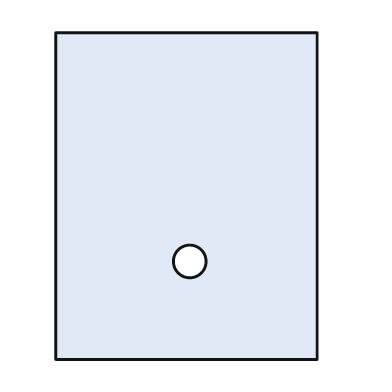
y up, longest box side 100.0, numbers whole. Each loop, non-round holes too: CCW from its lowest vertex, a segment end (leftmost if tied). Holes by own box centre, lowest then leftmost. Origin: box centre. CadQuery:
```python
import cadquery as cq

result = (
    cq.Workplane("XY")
    .moveTo(-40.0, -50.0)
    .lineTo(40.0, -50.0)
    .lineTo(40.0, 50.0)
    .lineTo(-40.0, 50.0)
    .close()
    .moveTo(1.0, -20.0)
    .circle(5.0)
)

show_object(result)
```